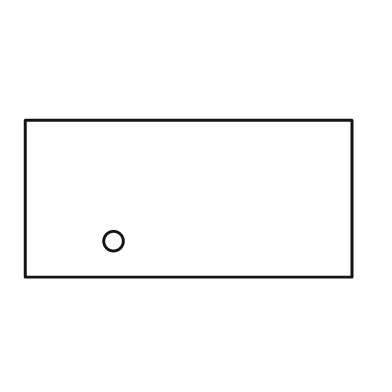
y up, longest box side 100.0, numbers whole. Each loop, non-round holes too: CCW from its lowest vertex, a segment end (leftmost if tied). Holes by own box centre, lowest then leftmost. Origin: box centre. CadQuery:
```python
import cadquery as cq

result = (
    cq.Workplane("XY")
    .moveTo(-50.0, -24.0)
    .lineTo(50.0, -24.0)
    .lineTo(50.0, 24.0)
    .lineTo(-50.0, 24.0)
    .close()
    .moveTo(-23.0, -13.0)
    .circle(3.0)
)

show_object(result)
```